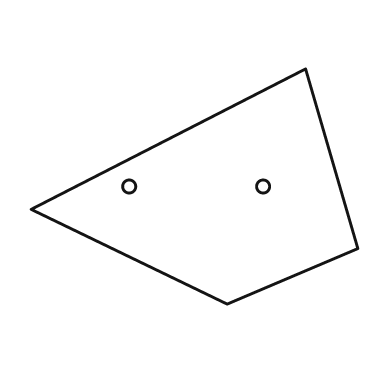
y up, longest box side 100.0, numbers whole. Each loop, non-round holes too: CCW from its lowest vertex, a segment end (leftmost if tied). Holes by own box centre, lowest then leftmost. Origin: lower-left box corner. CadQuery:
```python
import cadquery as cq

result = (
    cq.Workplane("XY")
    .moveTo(60.0, 0.0)
    .lineTo(100.0, 17.0)
    .lineTo(84.0, 72.0)
    .lineTo(0.0, 29.0)
    .close()
    .moveTo(30.0, 36.0)
    .circle(2.0)
    .moveTo(71.0, 36.0)
    .circle(2.0)
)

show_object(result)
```